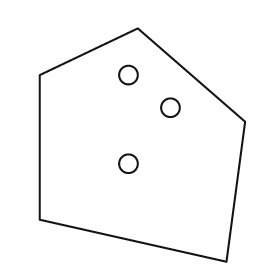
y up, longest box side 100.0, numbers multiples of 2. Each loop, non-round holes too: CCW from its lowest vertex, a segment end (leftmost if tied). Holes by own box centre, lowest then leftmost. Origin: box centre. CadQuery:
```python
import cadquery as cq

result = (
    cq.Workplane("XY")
    .moveTo(36.0, -50.0)
    .lineTo(44.0, 10.0)
    .lineTo(-2.0, 50.0)
    .lineTo(-44.0, 30.0)
    .lineTo(-44.0, -32.0)
    .close()
    .moveTo(-6.0, -8.0)
    .circle(4.0)
    .moveTo(12.0, 16.0)
    .circle(4.0)
    .moveTo(-6.0, 30.0)
    .circle(4.0)
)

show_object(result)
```